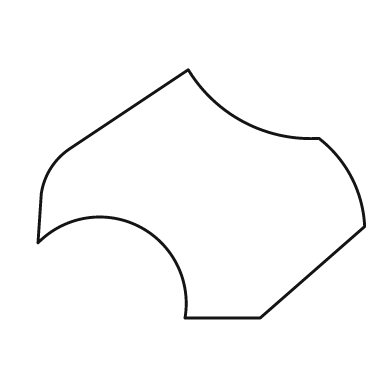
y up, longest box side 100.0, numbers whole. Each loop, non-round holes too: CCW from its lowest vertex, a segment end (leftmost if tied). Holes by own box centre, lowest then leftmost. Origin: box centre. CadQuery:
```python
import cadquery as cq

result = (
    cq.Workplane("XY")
    .moveTo(-5.0, -38.0)
    .lineTo(18.0, -38.0)
    .lineTo(50.0, -10.0)
    .threePointArc((46.0, 5.0), (36.0, 17.0))
    .threePointArc((13.0, 22.0), (-4.0, 38.0))
    .lineTo(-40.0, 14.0)
    .threePointArc((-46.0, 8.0), (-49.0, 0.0))
    .lineTo(-50.0, -15.0)
    .threePointArc((-19.0, -10.0), (-5.0, -38.0))
    .close()
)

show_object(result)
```